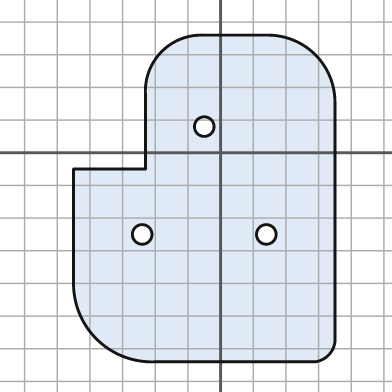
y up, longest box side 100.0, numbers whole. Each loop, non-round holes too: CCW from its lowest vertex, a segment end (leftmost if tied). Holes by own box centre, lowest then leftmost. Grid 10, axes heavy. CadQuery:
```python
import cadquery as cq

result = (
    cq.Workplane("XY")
    .moveTo(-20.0, -64.0)
    .lineTo(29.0, -64.0)
    .threePointArc((33.0, -62.0), (35.0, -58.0))
    .lineTo(35.0, 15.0)
    .threePointArc((29.0, 30.0), (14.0, 36.0))
    .lineTo(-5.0, 36.0)
    .threePointArc((-18.0, 31.0), (-23.0, 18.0))
    .lineTo(-23.0, -5.0)
    .lineTo(-45.0, -5.0)
    .lineTo(-45.0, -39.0)
    .threePointArc((-38.0, -57.0), (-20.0, -64.0))
    .close()
    .moveTo(-24.0, -25.0)
    .circle(3.0)
    .moveTo(14.0, -25.0)
    .circle(3.0)
    .moveTo(-5.0, 8.0)
    .circle(3.0)
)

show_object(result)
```